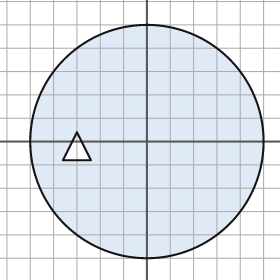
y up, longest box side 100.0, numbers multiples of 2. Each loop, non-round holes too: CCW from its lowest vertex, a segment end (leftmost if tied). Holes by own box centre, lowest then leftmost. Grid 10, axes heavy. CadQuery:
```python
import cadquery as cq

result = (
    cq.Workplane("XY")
    .moveTo(0.0, 0.0)
    .circle(50.0)
    .moveTo(-36.0, -8.0)
    .lineTo(-24.0, -8.0)
    .lineTo(-30.0, 4.0)
    .close()
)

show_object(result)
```